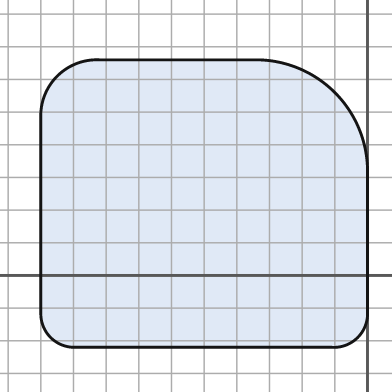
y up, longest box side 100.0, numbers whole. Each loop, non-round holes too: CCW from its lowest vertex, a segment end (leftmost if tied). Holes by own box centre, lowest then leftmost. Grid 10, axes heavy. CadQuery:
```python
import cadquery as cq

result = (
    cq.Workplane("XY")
    .moveTo(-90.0, -22.0)
    .lineTo(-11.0, -22.0)
    .threePointArc((-3.0, -19.0), (0.0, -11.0))
    .lineTo(0.0, 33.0)
    .threePointArc((-10.0, 56.0), (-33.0, 66.0))
    .lineTo(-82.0, 66.0)
    .threePointArc((-95.0, 61.0), (-100.0, 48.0))
    .lineTo(-100.0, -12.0)
    .threePointArc((-97.0, -19.0), (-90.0, -22.0))
    .close()
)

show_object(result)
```